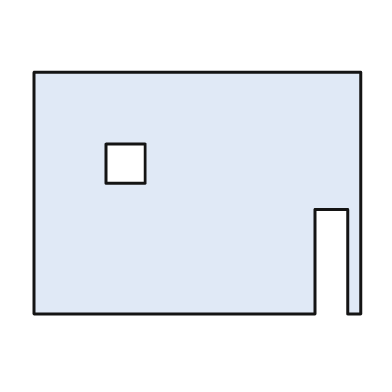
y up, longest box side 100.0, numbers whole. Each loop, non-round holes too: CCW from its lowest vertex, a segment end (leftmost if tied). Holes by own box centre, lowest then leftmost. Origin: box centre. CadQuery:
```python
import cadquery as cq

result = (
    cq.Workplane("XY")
    .moveTo(-50.0, -37.0)
    .lineTo(36.0, -37.0)
    .lineTo(36.0, -5.0)
    .lineTo(46.0, -5.0)
    .lineTo(46.0, -37.0)
    .lineTo(50.0, -37.0)
    .lineTo(50.0, 37.0)
    .lineTo(-50.0, 37.0)
    .close()
    .moveTo(-28.0, 3.0)
    .lineTo(-16.0, 3.0)
    .lineTo(-16.0, 15.0)
    .lineTo(-28.0, 15.0)
    .close()
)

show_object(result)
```